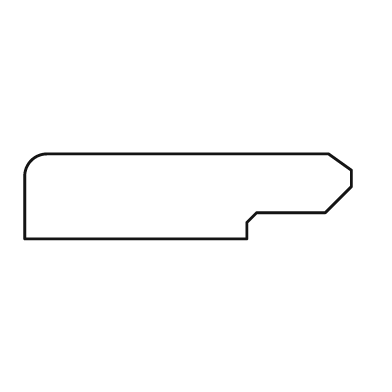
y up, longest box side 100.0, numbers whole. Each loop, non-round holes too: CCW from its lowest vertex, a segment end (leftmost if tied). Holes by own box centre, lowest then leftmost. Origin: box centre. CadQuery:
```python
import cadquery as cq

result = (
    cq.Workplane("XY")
    .moveTo(-50.0, -13.0)
    .lineTo(18.0, -13.0)
    .lineTo(18.0, -8.0)
    .lineTo(21.0, -5.0)
    .lineTo(42.0, -5.0)
    .lineTo(50.0, 3.0)
    .lineTo(50.0, 8.0)
    .lineTo(43.0, 13.0)
    .lineTo(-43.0, 13.0)
    .threePointArc((-48.0, 11.0), (-50.0, 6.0))
    .close()
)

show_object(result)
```